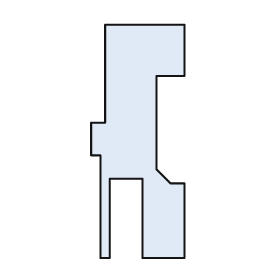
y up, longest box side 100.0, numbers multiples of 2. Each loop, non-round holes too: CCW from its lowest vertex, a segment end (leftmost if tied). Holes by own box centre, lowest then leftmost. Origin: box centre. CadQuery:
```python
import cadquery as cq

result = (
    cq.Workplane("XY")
    .moveTo(-16.0, -50.0)
    .lineTo(-12.0, -50.0)
    .lineTo(-12.0, -16.0)
    .lineTo(2.0, -16.0)
    .lineTo(2.0, -50.0)
    .lineTo(20.0, -50.0)
    .lineTo(20.0, -18.0)
    .lineTo(14.0, -18.0)
    .lineTo(8.0, -12.0)
    .lineTo(8.0, 28.0)
    .lineTo(20.0, 28.0)
    .lineTo(20.0, 50.0)
    .lineTo(-14.0, 50.0)
    .lineTo(-14.0, 8.0)
    .lineTo(-20.0, 8.0)
    .lineTo(-20.0, -6.0)
    .lineTo(-16.0, -6.0)
    .close()
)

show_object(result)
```